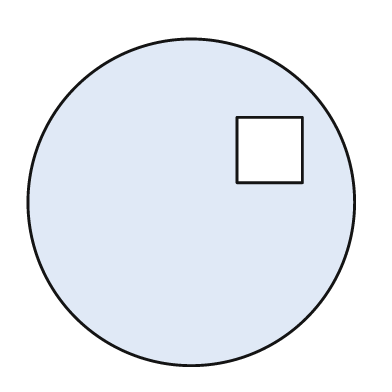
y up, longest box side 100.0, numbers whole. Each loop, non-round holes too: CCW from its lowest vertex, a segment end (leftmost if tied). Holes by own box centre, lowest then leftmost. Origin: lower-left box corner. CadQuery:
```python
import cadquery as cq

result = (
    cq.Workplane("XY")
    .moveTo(50.0, 50.0)
    .circle(50.0)
    .moveTo(64.0, 56.0)
    .lineTo(84.0, 56.0)
    .lineTo(84.0, 76.0)
    .lineTo(64.0, 76.0)
    .close()
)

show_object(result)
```